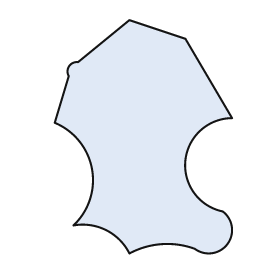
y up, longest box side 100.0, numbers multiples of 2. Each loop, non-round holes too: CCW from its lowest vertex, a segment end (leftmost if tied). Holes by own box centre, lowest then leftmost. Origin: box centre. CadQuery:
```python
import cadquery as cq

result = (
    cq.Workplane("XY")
    .moveTo(-6.0, -50.0)
    .threePointArc((8.0, -46.0), (22.0, -48.0))
    .threePointArc((36.0, -46.0), (34.0, -32.0))
    .threePointArc((18.0, -10.0), (38.0, 8.0))
    .lineTo(18.0, 42.0)
    .lineTo(-6.0, 50.0)
    .lineTo(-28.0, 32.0)
    .threePointArc((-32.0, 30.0), (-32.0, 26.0))
    .lineTo(-38.0, 6.0)
    .threePointArc((-22.0, -14.0), (-30.0, -38.0))
    .threePointArc((-16.0, -40.0), (-6.0, -50.0))
    .close()
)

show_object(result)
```